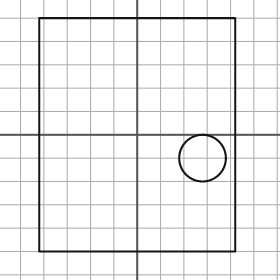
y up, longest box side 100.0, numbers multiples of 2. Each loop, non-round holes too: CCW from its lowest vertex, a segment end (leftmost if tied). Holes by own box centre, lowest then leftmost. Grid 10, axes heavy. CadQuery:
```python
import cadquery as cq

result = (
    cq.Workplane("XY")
    .moveTo(-42.0, -50.0)
    .lineTo(42.0, -50.0)
    .lineTo(42.0, 50.0)
    .lineTo(-42.0, 50.0)
    .close()
    .moveTo(28.0, -10.0)
    .circle(10.0)
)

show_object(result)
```